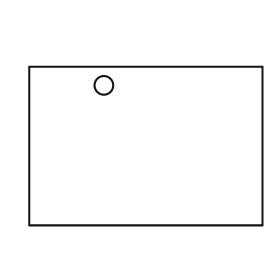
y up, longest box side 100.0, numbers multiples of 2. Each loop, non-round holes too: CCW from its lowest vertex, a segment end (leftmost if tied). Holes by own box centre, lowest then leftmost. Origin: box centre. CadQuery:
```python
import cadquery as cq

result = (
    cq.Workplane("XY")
    .moveTo(-50.0, -34.0)
    .lineTo(50.0, -34.0)
    .lineTo(50.0, 34.0)
    .lineTo(-50.0, 34.0)
    .close()
    .moveTo(-18.0, 26.0)
    .circle(4.0)
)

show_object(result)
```